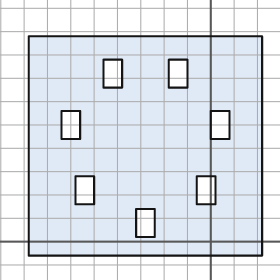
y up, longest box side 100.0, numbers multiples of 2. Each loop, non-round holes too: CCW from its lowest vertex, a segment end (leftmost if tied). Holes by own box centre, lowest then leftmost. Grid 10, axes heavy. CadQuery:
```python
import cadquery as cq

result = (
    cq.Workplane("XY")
    .moveTo(-78.0, -6.0)
    .lineTo(22.0, -6.0)
    .lineTo(22.0, 88.0)
    .lineTo(-78.0, 88.0)
    .close()
    .moveTo(-32.0, 2.0)
    .lineTo(-24.0, 2.0)
    .lineTo(-24.0, 14.0)
    .lineTo(-32.0, 14.0)
    .close()
    .moveTo(-58.0, 16.0)
    .lineTo(-50.0, 16.0)
    .lineTo(-50.0, 28.0)
    .lineTo(-58.0, 28.0)
    .close()
    .moveTo(-6.0, 16.0)
    .lineTo(2.0, 16.0)
    .lineTo(2.0, 28.0)
    .lineTo(-6.0, 28.0)
    .close()
    .moveTo(-64.0, 44.0)
    .lineTo(-56.0, 44.0)
    .lineTo(-56.0, 56.0)
    .lineTo(-64.0, 56.0)
    .close()
    .moveTo(0.0, 44.0)
    .lineTo(8.0, 44.0)
    .lineTo(8.0, 56.0)
    .lineTo(0.0, 56.0)
    .close()
    .moveTo(-46.0, 66.0)
    .lineTo(-38.0, 66.0)
    .lineTo(-38.0, 78.0)
    .lineTo(-46.0, 78.0)
    .close()
    .moveTo(-18.0, 66.0)
    .lineTo(-10.0, 66.0)
    .lineTo(-10.0, 78.0)
    .lineTo(-18.0, 78.0)
    .close()
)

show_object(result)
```